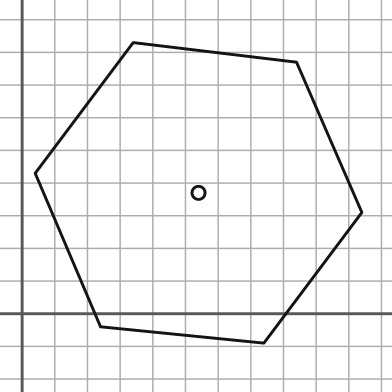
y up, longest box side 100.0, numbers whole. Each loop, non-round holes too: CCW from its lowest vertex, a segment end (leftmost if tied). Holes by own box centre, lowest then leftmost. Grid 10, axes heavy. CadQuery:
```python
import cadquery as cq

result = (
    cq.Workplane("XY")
    .moveTo(74.0, -9.0)
    .lineTo(104.0, 31.0)
    .lineTo(84.0, 77.0)
    .lineTo(34.0, 83.0)
    .lineTo(4.0, 43.0)
    .lineTo(24.0, -4.0)
    .close()
    .moveTo(54.0, 37.0)
    .circle(2.0)
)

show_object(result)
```